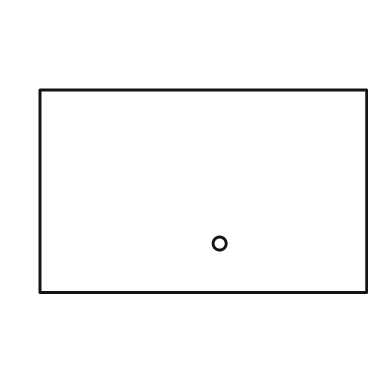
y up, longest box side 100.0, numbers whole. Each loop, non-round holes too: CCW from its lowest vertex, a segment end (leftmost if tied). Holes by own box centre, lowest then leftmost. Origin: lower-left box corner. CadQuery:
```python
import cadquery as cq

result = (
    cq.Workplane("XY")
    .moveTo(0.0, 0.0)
    .lineTo(100.0, 0.0)
    .lineTo(100.0, 62.0)
    .lineTo(0.0, 62.0)
    .close()
    .moveTo(55.0, 15.0)
    .circle(2.0)
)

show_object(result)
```